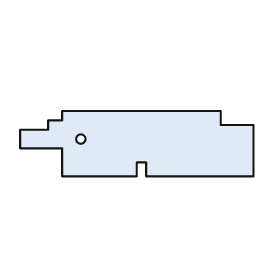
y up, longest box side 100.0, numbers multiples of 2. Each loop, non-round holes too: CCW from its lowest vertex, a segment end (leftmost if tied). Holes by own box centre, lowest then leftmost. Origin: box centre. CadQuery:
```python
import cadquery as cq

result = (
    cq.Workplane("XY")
    .moveTo(-32.0, -14.0)
    .lineTo(0.0, -14.0)
    .lineTo(0.0, -8.0)
    .lineTo(4.0, -8.0)
    .lineTo(4.0, -14.0)
    .lineTo(50.0, -14.0)
    .lineTo(50.0, 8.0)
    .lineTo(36.0, 8.0)
    .lineTo(36.0, 14.0)
    .lineTo(-32.0, 14.0)
    .lineTo(-32.0, 10.0)
    .lineTo(-38.0, 10.0)
    .lineTo(-38.0, 6.0)
    .lineTo(-50.0, 6.0)
    .lineTo(-50.0, -2.0)
    .lineTo(-32.0, -2.0)
    .close()
    .moveTo(-24.0, 2.0)
    .circle(2.0)
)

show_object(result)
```